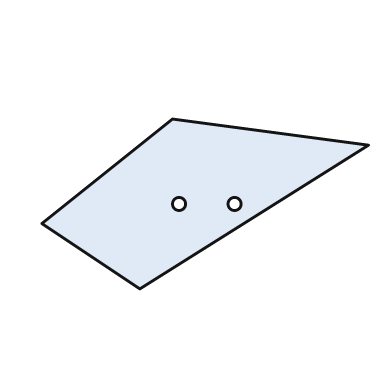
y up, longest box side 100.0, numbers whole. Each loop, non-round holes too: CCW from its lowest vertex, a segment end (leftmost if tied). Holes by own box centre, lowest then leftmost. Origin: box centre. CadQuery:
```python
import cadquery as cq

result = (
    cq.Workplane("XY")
    .moveTo(-20.0, -26.0)
    .lineTo(50.0, 18.0)
    .lineTo(-10.0, 26.0)
    .lineTo(-50.0, -6.0)
    .close()
    .moveTo(-8.0, 0.0)
    .circle(2.0)
    .moveTo(9.0, 0.0)
    .circle(2.0)
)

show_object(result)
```